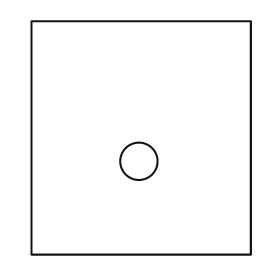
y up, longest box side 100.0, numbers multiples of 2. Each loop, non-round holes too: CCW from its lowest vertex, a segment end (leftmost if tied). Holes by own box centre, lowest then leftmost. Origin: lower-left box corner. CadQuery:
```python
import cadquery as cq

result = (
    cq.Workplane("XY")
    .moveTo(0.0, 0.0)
    .lineTo(94.0, 0.0)
    .lineTo(94.0, 100.0)
    .lineTo(0.0, 100.0)
    .close()
    .moveTo(46.0, 40.0)
    .circle(8.0)
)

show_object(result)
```